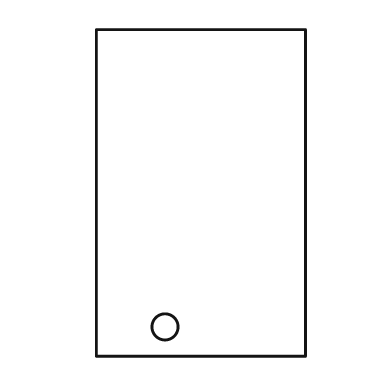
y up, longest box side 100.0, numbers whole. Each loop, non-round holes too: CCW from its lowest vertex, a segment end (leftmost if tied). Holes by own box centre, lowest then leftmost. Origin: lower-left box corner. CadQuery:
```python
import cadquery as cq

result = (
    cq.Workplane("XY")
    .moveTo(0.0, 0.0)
    .lineTo(64.0, 0.0)
    .lineTo(64.0, 100.0)
    .lineTo(0.0, 100.0)
    .close()
    .moveTo(21.0, 9.0)
    .circle(4.0)
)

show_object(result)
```